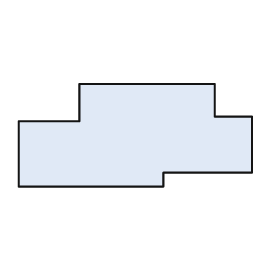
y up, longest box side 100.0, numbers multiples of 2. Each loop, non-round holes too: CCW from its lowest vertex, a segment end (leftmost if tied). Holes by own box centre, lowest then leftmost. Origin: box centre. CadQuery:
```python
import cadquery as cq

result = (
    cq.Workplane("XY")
    .moveTo(-50.0, -22.0)
    .lineTo(12.0, -22.0)
    .lineTo(12.0, -16.0)
    .lineTo(50.0, -16.0)
    .lineTo(50.0, 8.0)
    .lineTo(34.0, 8.0)
    .lineTo(34.0, 22.0)
    .lineTo(-24.0, 22.0)
    .lineTo(-24.0, 6.0)
    .lineTo(-50.0, 6.0)
    .close()
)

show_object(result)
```